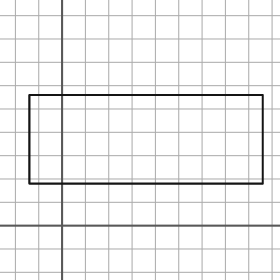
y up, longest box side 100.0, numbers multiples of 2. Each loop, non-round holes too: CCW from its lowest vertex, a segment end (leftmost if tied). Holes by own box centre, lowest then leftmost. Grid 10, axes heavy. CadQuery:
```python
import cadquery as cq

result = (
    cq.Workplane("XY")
    .moveTo(-14.0, 18.0)
    .lineTo(86.0, 18.0)
    .lineTo(86.0, 56.0)
    .lineTo(-14.0, 56.0)
    .close()
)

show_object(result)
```